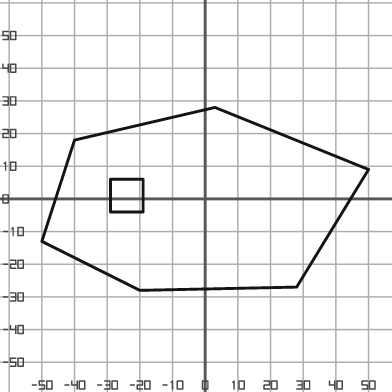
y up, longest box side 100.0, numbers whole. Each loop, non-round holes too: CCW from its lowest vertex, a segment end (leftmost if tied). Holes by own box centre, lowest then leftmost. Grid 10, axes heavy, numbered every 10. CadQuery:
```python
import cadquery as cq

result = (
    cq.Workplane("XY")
    .moveTo(-20.0, -28.0)
    .lineTo(28.0, -27.0)
    .lineTo(50.0, 9.0)
    .lineTo(3.0, 28.0)
    .lineTo(-40.0, 18.0)
    .lineTo(-50.0, -13.0)
    .close()
    .moveTo(-29.0, -4.0)
    .lineTo(-19.0, -4.0)
    .lineTo(-19.0, 6.0)
    .lineTo(-29.0, 6.0)
    .close()
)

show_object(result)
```